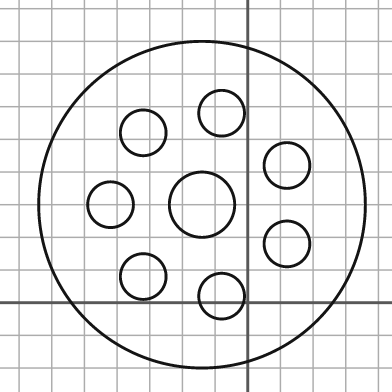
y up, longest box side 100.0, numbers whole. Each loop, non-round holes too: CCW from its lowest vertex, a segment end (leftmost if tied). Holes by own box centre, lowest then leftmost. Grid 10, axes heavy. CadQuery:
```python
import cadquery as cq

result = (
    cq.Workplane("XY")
    .moveTo(-14.0, 30.0)
    .circle(50.0)
    .moveTo(-8.0, 2.0)
    .circle(7.0)
    .moveTo(-32.0, 8.0)
    .circle(7.0)
    .moveTo(12.0, 18.0)
    .circle(7.0)
    .moveTo(-42.0, 30.0)
    .circle(7.0)
    .moveTo(-14.0, 30.0)
    .circle(10.0)
    .moveTo(12.0, 42.0)
    .circle(7.0)
    .moveTo(-32.0, 52.0)
    .circle(7.0)
    .moveTo(-8.0, 58.0)
    .circle(7.0)
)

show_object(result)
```